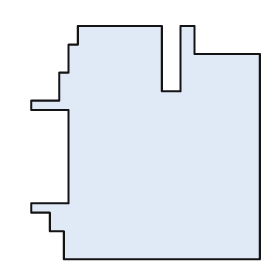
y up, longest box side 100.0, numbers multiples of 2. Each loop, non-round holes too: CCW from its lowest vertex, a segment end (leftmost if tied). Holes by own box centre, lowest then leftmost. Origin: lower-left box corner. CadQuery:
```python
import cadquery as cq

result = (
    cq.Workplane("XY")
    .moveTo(14.0, 0.0)
    .lineTo(98.0, 0.0)
    .lineTo(98.0, 88.0)
    .lineTo(70.0, 88.0)
    .lineTo(70.0, 100.0)
    .lineTo(64.0, 100.0)
    .lineTo(64.0, 72.0)
    .lineTo(56.0, 72.0)
    .lineTo(56.0, 100.0)
    .lineTo(20.0, 100.0)
    .lineTo(20.0, 92.0)
    .lineTo(16.0, 92.0)
    .lineTo(16.0, 80.0)
    .lineTo(12.0, 80.0)
    .lineTo(12.0, 68.0)
    .lineTo(0.0, 68.0)
    .lineTo(0.0, 64.0)
    .lineTo(16.0, 64.0)
    .lineTo(16.0, 24.0)
    .lineTo(0.0, 24.0)
    .lineTo(0.0, 20.0)
    .lineTo(8.0, 20.0)
    .lineTo(8.0, 12.0)
    .lineTo(14.0, 12.0)
    .close()
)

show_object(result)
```